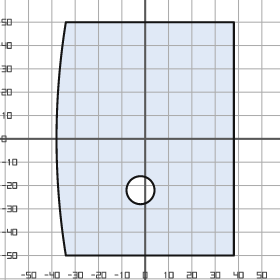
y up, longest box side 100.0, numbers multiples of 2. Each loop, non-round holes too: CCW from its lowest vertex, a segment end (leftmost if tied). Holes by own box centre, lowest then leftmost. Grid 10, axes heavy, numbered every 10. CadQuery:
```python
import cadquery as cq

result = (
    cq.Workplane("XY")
    .moveTo(-34.0, -50.0)
    .lineTo(38.0, -50.0)
    .lineTo(38.0, 50.0)
    .lineTo(-34.0, 50.0)
    .threePointArc((-38.0, 0.0), (-34.0, -50.0))
    .close()
    .moveTo(-2.0, -22.0)
    .circle(6.0)
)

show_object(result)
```